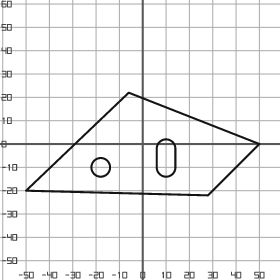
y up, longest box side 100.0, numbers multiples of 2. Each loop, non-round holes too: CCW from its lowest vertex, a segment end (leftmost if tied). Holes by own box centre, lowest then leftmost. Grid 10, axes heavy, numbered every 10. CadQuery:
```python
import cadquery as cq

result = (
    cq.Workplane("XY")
    .moveTo(28.0, -22.0)
    .lineTo(50.0, 0.0)
    .lineTo(-6.0, 22.0)
    .lineTo(-50.0, -20.0)
    .close()
    .moveTo(-18.0, -10.0)
    .circle(4.0)
    .moveTo(6.0, -10.0)
    .threePointArc((10.0, -14.0), (14.0, -10.0))
    .lineTo(14.0, -2.0)
    .threePointArc((10.0, 2.0), (6.0, -2.0))
    .close()
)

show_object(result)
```